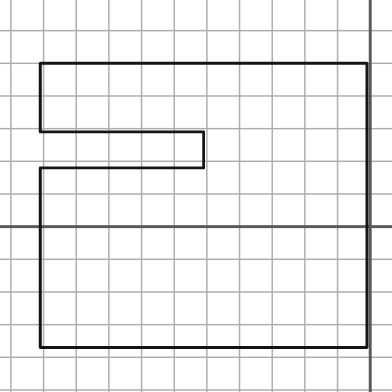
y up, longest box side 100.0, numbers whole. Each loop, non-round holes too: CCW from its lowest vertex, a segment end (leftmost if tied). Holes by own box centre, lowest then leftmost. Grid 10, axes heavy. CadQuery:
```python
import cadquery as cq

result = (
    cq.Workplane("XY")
    .moveTo(-101.0, -37.0)
    .lineTo(-1.0, -37.0)
    .lineTo(-1.0, 50.0)
    .lineTo(-101.0, 50.0)
    .lineTo(-101.0, 29.0)
    .lineTo(-51.0, 29.0)
    .lineTo(-51.0, 18.0)
    .lineTo(-101.0, 18.0)
    .close()
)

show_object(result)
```